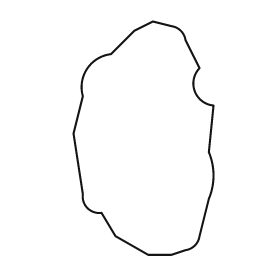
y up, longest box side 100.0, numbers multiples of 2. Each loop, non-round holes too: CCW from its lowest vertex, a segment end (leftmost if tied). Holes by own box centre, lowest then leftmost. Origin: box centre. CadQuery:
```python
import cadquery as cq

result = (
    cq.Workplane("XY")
    .moveTo(2.0, -50.0)
    .lineTo(12.0, -50.0)
    .lineTo(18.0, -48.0)
    .threePointArc((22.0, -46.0), (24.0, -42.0))
    .lineTo(28.0, -26.0)
    .threePointArc((30.0, -16.0), (28.0, -6.0))
    .lineTo(30.0, 14.0)
    .threePointArc((22.0, 20.0), (24.0, 30.0))
    .lineTo(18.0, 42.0)
    .threePointArc((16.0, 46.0), (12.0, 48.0))
    .lineTo(4.0, 50.0)
    .lineTo(-4.0, 46.0)
    .lineTo(-14.0, 36.0)
    .threePointArc((-24.0, 30.0), (-26.0, 18.0))
    .lineTo(-30.0, 2.0)
    .lineTo(-26.0, -24.0)
    .threePointArc((-24.0, -30.0), (-18.0, -32.0))
    .lineTo(-12.0, -42.0)
    .close()
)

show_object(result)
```